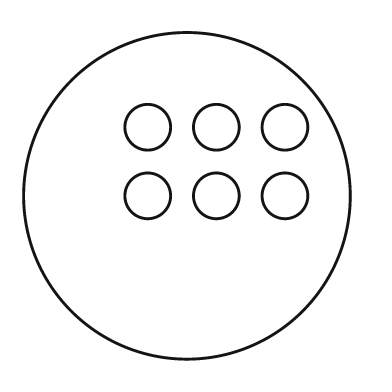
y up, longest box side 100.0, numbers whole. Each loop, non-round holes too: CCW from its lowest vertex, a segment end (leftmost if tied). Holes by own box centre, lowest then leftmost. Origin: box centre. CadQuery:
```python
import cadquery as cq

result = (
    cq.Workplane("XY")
    .moveTo(0.0, 0.0)
    .circle(50.0)
    .moveTo(-12.0, 0.0)
    .circle(7.0)
    .moveTo(9.0, 0.0)
    .circle(7.0)
    .moveTo(30.0, 0.0)
    .circle(7.0)
    .moveTo(-12.0, 21.0)
    .circle(7.0)
    .moveTo(9.0, 21.0)
    .circle(7.0)
    .moveTo(30.0, 21.0)
    .circle(7.0)
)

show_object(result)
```